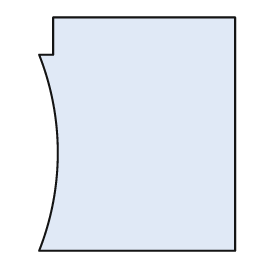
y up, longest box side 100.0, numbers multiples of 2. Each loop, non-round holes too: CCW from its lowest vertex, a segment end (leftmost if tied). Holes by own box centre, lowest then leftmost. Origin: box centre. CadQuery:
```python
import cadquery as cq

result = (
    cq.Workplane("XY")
    .moveTo(-42.0, -50.0)
    .lineTo(42.0, -50.0)
    .lineTo(42.0, 50.0)
    .lineTo(-36.0, 50.0)
    .lineTo(-36.0, 34.0)
    .lineTo(-42.0, 34.0)
    .threePointArc((-34.0, -8.0), (-42.0, -50.0))
    .close()
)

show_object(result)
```